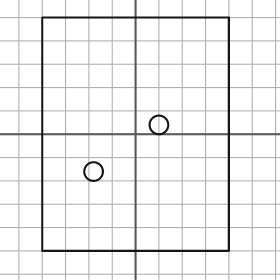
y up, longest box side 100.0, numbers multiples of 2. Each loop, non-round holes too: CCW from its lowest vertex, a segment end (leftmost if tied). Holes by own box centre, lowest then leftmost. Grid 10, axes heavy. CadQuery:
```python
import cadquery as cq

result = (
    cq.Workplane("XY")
    .moveTo(-40.0, -50.0)
    .lineTo(40.0, -50.0)
    .lineTo(40.0, 50.0)
    .lineTo(-40.0, 50.0)
    .close()
    .moveTo(-18.0, -16.0)
    .circle(4.0)
    .moveTo(10.0, 4.0)
    .circle(4.0)
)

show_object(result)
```